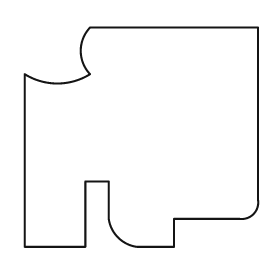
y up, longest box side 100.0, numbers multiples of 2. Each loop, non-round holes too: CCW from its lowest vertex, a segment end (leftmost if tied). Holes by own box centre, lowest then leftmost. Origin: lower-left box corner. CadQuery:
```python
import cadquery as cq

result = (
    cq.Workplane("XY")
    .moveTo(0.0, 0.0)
    .lineTo(26.0, 0.0)
    .lineTo(26.0, 28.0)
    .lineTo(36.0, 28.0)
    .lineTo(36.0, 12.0)
    .threePointArc((40.0, 4.0), (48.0, 0.0))
    .lineTo(64.0, 0.0)
    .lineTo(64.0, 12.0)
    .lineTo(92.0, 12.0)
    .threePointArc((98.0, 14.0), (100.0, 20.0))
    .lineTo(100.0, 94.0)
    .lineTo(28.0, 94.0)
    .threePointArc((24.0, 84.0), (28.0, 74.0))
    .threePointArc((14.0, 70.0), (0.0, 74.0))
    .close()
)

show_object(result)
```